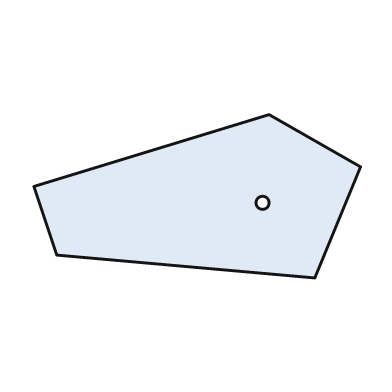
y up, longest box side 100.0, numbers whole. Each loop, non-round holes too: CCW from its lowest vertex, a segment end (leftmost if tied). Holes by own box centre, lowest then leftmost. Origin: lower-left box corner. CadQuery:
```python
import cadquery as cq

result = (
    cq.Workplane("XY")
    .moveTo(86.0, 0.0)
    .lineTo(100.0, 34.0)
    .lineTo(72.0, 50.0)
    .lineTo(0.0, 28.0)
    .lineTo(7.0, 7.0)
    .close()
    .moveTo(70.0, 23.0)
    .circle(2.0)
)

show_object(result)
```